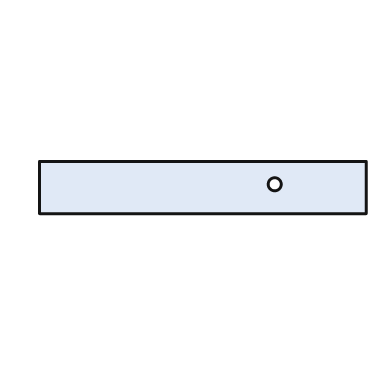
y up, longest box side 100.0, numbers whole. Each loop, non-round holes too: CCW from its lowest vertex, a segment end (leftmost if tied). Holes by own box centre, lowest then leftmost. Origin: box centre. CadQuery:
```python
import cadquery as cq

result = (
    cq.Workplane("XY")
    .moveTo(-50.0, -8.0)
    .lineTo(50.0, -8.0)
    .lineTo(50.0, 8.0)
    .lineTo(-50.0, 8.0)
    .close()
    .moveTo(22.0, 1.0)
    .circle(2.0)
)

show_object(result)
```